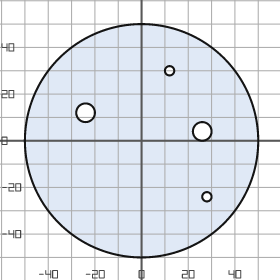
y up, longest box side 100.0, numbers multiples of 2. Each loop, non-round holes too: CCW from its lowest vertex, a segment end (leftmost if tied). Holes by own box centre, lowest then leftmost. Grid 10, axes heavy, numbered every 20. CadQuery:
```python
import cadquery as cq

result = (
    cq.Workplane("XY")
    .moveTo(0.0, 0.0)
    .circle(50.0)
    .moveTo(28.0, -24.0)
    .circle(2.0)
    .moveTo(26.0, 4.0)
    .circle(4.0)
    .moveTo(-24.0, 12.0)
    .circle(4.0)
    .moveTo(12.0, 30.0)
    .circle(2.0)
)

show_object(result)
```